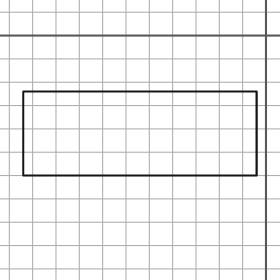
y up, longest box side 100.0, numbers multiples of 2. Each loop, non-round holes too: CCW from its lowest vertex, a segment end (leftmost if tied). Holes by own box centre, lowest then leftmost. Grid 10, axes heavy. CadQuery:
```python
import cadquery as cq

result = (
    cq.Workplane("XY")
    .moveTo(-104.0, -60.0)
    .lineTo(-4.0, -60.0)
    .lineTo(-4.0, -24.0)
    .lineTo(-104.0, -24.0)
    .close()
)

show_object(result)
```